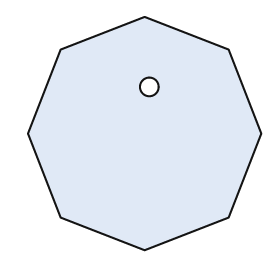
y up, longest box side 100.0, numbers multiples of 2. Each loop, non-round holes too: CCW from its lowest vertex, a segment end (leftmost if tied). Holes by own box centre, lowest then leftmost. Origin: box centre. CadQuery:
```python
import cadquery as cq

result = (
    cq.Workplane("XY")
    .moveTo(0.0, -50.0)
    .lineTo(36.0, -36.0)
    .lineTo(50.0, 0.0)
    .lineTo(36.0, 36.0)
    .lineTo(0.0, 50.0)
    .lineTo(-36.0, 36.0)
    .lineTo(-50.0, 0.0)
    .lineTo(-36.0, -36.0)
    .close()
    .moveTo(2.0, 20.0)
    .circle(4.0)
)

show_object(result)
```